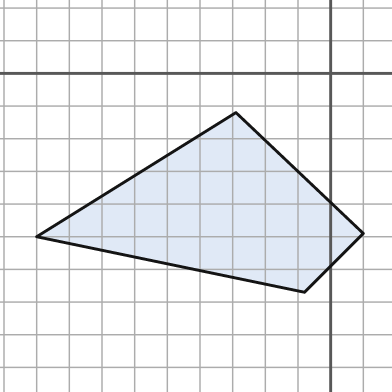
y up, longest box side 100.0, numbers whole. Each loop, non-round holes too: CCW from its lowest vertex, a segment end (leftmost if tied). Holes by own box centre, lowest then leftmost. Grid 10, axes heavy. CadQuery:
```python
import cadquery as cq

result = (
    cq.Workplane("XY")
    .moveTo(-8.0, -67.0)
    .lineTo(10.0, -49.0)
    .lineTo(-29.0, -12.0)
    .lineTo(-90.0, -50.0)
    .close()
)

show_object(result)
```